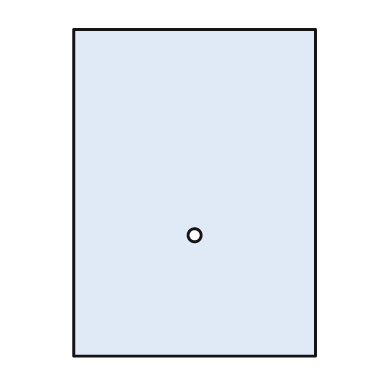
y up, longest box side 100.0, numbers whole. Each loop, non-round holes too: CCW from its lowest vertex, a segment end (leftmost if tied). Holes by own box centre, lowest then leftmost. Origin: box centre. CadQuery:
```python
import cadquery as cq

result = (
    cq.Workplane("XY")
    .moveTo(-37.0, -50.0)
    .lineTo(37.0, -50.0)
    .lineTo(37.0, 50.0)
    .lineTo(-37.0, 50.0)
    .close()
    .moveTo(0.0, -13.0)
    .circle(2.0)
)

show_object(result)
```